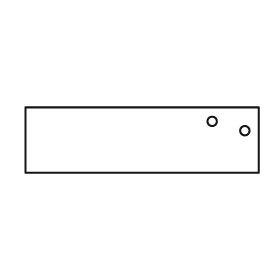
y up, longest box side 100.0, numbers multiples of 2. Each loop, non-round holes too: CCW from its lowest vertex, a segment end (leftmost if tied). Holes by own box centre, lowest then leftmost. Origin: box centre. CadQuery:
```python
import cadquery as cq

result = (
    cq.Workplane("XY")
    .moveTo(-50.0, -14.0)
    .lineTo(50.0, -14.0)
    .lineTo(50.0, 14.0)
    .lineTo(-50.0, 14.0)
    .close()
    .moveTo(44.0, 4.0)
    .circle(2.0)
    .moveTo(30.0, 8.0)
    .circle(2.0)
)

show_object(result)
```